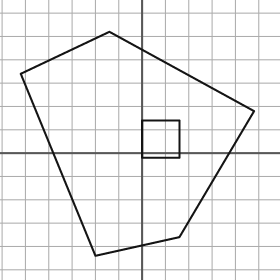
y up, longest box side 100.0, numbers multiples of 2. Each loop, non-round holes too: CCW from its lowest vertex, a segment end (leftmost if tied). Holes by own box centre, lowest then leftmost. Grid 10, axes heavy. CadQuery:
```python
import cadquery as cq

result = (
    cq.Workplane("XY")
    .moveTo(-20.0, -44.0)
    .lineTo(16.0, -36.0)
    .lineTo(48.0, 18.0)
    .lineTo(-14.0, 52.0)
    .lineTo(-52.0, 34.0)
    .close()
    .moveTo(0.0, -2.0)
    .lineTo(16.0, -2.0)
    .lineTo(16.0, 14.0)
    .lineTo(0.0, 14.0)
    .close()
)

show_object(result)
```